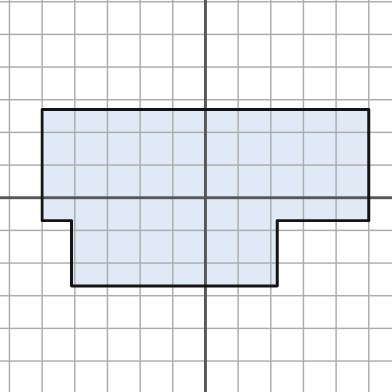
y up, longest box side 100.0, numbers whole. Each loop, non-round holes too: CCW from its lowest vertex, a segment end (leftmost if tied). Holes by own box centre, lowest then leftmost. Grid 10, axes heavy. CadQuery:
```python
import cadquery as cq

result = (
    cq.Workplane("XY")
    .moveTo(-41.0, -27.0)
    .lineTo(22.0, -27.0)
    .lineTo(22.0, -7.0)
    .lineTo(50.0, -7.0)
    .lineTo(50.0, 27.0)
    .lineTo(-50.0, 27.0)
    .lineTo(-50.0, -7.0)
    .lineTo(-41.0, -7.0)
    .close()
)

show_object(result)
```